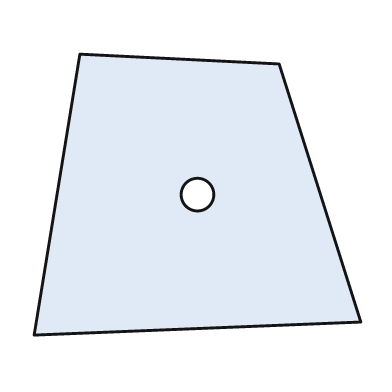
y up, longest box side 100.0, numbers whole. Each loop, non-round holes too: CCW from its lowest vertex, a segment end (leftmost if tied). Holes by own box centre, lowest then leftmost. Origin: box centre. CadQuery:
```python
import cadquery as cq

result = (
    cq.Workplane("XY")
    .moveTo(-50.0, -43.0)
    .lineTo(50.0, -39.0)
    .lineTo(25.0, 40.0)
    .lineTo(-36.0, 43.0)
    .close()
    .moveTo(0.0, 0.0)
    .circle(5.0)
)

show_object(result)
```